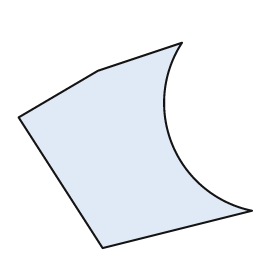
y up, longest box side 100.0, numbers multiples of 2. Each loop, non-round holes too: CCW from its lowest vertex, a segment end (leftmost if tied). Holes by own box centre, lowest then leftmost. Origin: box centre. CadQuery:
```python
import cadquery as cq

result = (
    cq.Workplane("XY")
    .moveTo(-14.0, -44.0)
    .lineTo(50.0, -28.0)
    .threePointArc((16.0, 0.0), (20.0, 44.0))
    .lineTo(-16.0, 32.0)
    .lineTo(-50.0, 12.0)
    .close()
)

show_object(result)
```